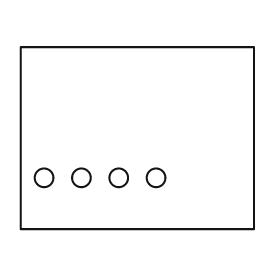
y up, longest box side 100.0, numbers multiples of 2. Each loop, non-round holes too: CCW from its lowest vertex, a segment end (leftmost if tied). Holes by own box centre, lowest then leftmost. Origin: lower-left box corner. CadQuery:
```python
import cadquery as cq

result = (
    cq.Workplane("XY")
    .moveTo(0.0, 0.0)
    .lineTo(100.0, 0.0)
    .lineTo(100.0, 78.0)
    .lineTo(0.0, 78.0)
    .close()
    .moveTo(10.0, 22.0)
    .circle(4.0)
    .moveTo(26.0, 22.0)
    .circle(4.0)
    .moveTo(42.0, 22.0)
    .circle(4.0)
    .moveTo(58.0, 22.0)
    .circle(4.0)
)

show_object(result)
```